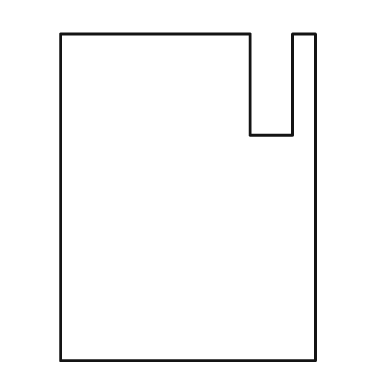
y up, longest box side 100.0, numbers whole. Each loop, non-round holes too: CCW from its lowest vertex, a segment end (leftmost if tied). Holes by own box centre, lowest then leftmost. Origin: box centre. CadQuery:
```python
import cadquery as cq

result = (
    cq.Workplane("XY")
    .moveTo(-39.0, -50.0)
    .lineTo(39.0, -50.0)
    .lineTo(39.0, 50.0)
    .lineTo(32.0, 50.0)
    .lineTo(32.0, 19.0)
    .lineTo(19.0, 19.0)
    .lineTo(19.0, 50.0)
    .lineTo(-39.0, 50.0)
    .close()
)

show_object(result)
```